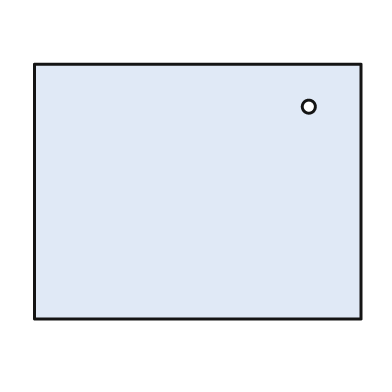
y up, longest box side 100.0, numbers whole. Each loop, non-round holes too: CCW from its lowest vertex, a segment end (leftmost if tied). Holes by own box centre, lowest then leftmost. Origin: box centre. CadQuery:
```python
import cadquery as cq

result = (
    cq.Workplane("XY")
    .moveTo(-50.0, -39.0)
    .lineTo(50.0, -39.0)
    .lineTo(50.0, 39.0)
    .lineTo(-50.0, 39.0)
    .close()
    .moveTo(34.0, 26.0)
    .circle(2.0)
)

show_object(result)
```